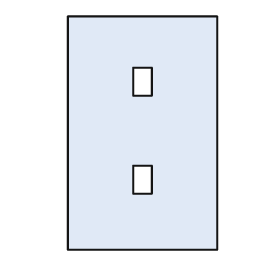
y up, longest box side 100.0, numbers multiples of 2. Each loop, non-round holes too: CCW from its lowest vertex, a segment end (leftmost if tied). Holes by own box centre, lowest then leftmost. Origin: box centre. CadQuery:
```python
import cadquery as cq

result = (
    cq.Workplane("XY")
    .moveTo(-32.0, -50.0)
    .lineTo(32.0, -50.0)
    .lineTo(32.0, 50.0)
    .lineTo(-32.0, 50.0)
    .close()
    .moveTo(-4.0, -26.0)
    .lineTo(4.0, -26.0)
    .lineTo(4.0, -14.0)
    .lineTo(-4.0, -14.0)
    .close()
    .moveTo(-4.0, 16.0)
    .lineTo(4.0, 16.0)
    .lineTo(4.0, 28.0)
    .lineTo(-4.0, 28.0)
    .close()
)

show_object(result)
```